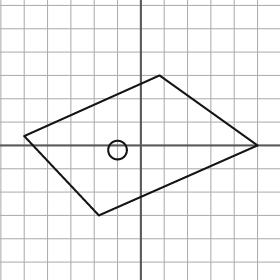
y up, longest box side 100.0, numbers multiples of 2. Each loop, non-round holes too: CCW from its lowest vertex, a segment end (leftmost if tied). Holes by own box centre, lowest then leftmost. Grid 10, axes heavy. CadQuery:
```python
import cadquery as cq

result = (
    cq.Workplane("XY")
    .moveTo(-18.0, -30.0)
    .lineTo(50.0, 0.0)
    .lineTo(8.0, 30.0)
    .lineTo(-50.0, 4.0)
    .close()
    .moveTo(-10.0, -2.0)
    .circle(4.0)
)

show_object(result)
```